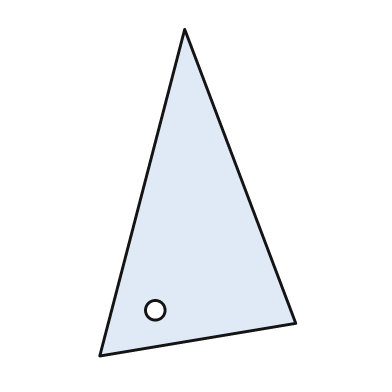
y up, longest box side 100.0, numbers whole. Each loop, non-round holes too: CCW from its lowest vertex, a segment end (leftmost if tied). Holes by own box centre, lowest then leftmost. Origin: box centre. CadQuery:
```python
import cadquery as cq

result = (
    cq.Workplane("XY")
    .moveTo(-30.0, -50.0)
    .lineTo(30.0, -40.0)
    .lineTo(-4.0, 50.0)
    .close()
    .moveTo(-13.0, -36.0)
    .circle(3.0)
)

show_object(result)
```